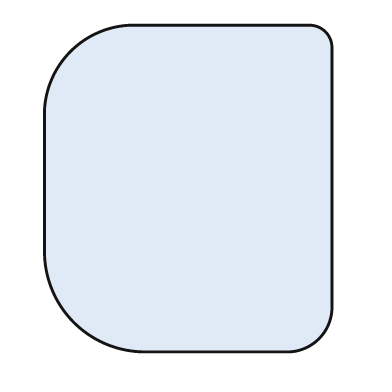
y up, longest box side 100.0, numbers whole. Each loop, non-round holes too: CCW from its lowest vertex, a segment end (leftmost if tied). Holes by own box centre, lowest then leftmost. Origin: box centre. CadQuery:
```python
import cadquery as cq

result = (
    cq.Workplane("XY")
    .moveTo(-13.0, -50.0)
    .lineTo(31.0, -50.0)
    .threePointArc((40.0, -46.0), (44.0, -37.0))
    .lineTo(44.0, 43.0)
    .threePointArc((42.0, 48.0), (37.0, 50.0))
    .lineTo(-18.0, 50.0)
    .threePointArc((-36.0, 42.0), (-44.0, 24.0))
    .lineTo(-44.0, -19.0)
    .threePointArc((-35.0, -41.0), (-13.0, -50.0))
    .close()
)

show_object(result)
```